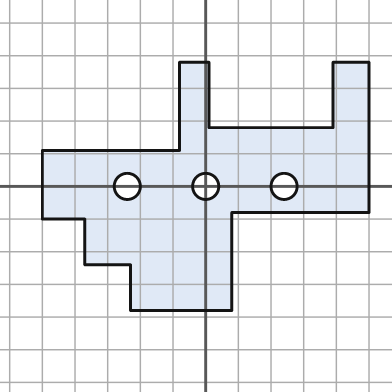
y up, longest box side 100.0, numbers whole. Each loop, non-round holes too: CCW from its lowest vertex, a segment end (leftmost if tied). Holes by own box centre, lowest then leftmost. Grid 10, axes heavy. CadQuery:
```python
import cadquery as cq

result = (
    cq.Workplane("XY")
    .moveTo(-23.0, -38.0)
    .lineTo(8.0, -38.0)
    .lineTo(8.0, -8.0)
    .lineTo(50.0, -8.0)
    .lineTo(50.0, 38.0)
    .lineTo(39.0, 38.0)
    .lineTo(39.0, 18.0)
    .lineTo(1.0, 18.0)
    .lineTo(1.0, 38.0)
    .lineTo(-8.0, 38.0)
    .lineTo(-8.0, 11.0)
    .lineTo(-50.0, 11.0)
    .lineTo(-50.0, -10.0)
    .lineTo(-37.0, -10.0)
    .lineTo(-37.0, -24.0)
    .lineTo(-23.0, -24.0)
    .close()
    .moveTo(-24.0, 0.0)
    .circle(4.0)
    .moveTo(0.0, 0.0)
    .circle(4.0)
    .moveTo(24.0, 0.0)
    .circle(4.0)
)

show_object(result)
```